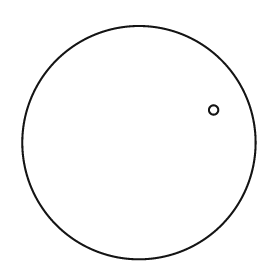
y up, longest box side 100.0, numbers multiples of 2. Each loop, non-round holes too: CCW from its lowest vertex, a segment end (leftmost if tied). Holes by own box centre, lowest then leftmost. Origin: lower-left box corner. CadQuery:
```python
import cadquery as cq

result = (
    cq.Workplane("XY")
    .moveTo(50.0, 50.0)
    .circle(50.0)
    .moveTo(82.0, 64.0)
    .circle(2.0)
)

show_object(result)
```